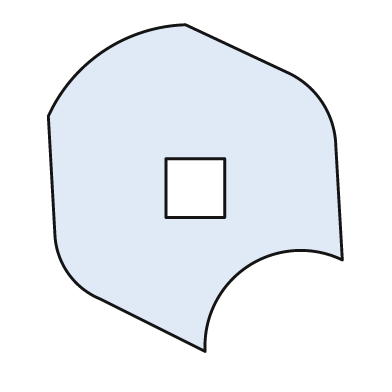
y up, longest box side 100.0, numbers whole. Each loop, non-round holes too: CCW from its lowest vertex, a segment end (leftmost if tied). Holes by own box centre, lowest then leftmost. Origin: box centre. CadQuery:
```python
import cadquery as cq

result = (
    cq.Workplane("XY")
    .moveTo(3.0, -50.0)
    .threePointArc((16.0, -24.0), (45.0, -22.0))
    .lineTo(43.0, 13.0)
    .threePointArc((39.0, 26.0), (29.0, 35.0))
    .lineTo(-3.0, 50.0)
    .threePointArc((-28.0, 42.0), (-45.0, 22.0))
    .lineTo(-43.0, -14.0)
    .threePointArc((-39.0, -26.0), (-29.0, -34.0))
    .close()
    .moveTo(-9.0, -9.0)
    .lineTo(9.0, -9.0)
    .lineTo(9.0, 9.0)
    .lineTo(-9.0, 9.0)
    .close()
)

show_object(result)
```